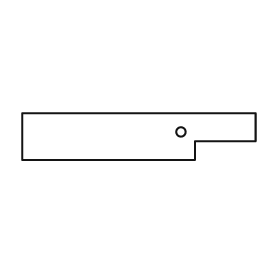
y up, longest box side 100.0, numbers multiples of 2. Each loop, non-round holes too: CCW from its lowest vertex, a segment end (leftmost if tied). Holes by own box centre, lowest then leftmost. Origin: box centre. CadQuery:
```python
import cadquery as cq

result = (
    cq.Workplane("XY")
    .moveTo(-50.0, -10.0)
    .lineTo(24.0, -10.0)
    .lineTo(24.0, -2.0)
    .lineTo(50.0, -2.0)
    .lineTo(50.0, 10.0)
    .lineTo(-50.0, 10.0)
    .close()
    .moveTo(18.0, 2.0)
    .circle(2.0)
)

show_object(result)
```